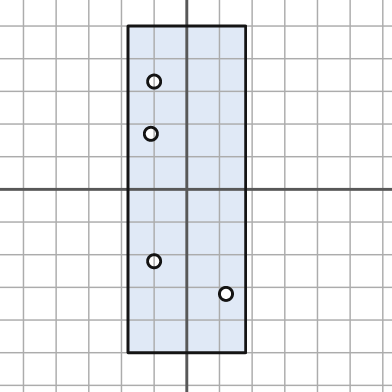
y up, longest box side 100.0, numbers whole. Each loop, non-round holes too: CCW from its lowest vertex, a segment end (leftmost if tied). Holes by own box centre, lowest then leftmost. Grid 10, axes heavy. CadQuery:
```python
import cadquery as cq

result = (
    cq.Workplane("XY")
    .moveTo(-18.0, -50.0)
    .lineTo(18.0, -50.0)
    .lineTo(18.0, 50.0)
    .lineTo(-18.0, 50.0)
    .close()
    .moveTo(12.0, -32.0)
    .circle(2.0)
    .moveTo(-10.0, -22.0)
    .circle(2.0)
    .moveTo(-11.0, 17.0)
    .circle(2.0)
    .moveTo(-10.0, 33.0)
    .circle(2.0)
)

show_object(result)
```